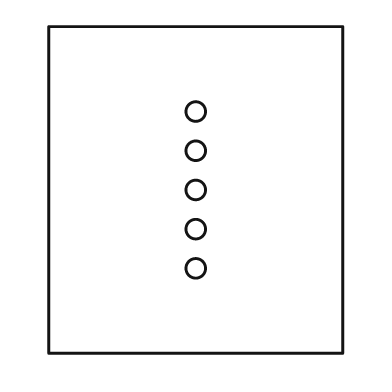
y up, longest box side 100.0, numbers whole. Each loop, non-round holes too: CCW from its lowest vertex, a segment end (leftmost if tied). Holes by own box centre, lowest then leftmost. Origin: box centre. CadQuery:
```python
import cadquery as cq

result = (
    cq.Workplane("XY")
    .moveTo(-45.0, -50.0)
    .lineTo(45.0, -50.0)
    .lineTo(45.0, 50.0)
    .lineTo(-45.0, 50.0)
    .close()
    .moveTo(0.0, -24.0)
    .circle(3.0)
    .moveTo(0.0, -12.0)
    .circle(3.0)
    .moveTo(0.0, 0.0)
    .circle(3.0)
    .moveTo(0.0, 12.0)
    .circle(3.0)
    .moveTo(0.0, 24.0)
    .circle(3.0)
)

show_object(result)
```